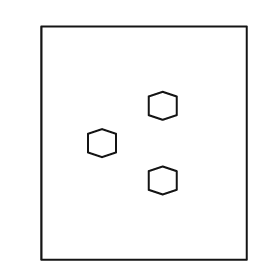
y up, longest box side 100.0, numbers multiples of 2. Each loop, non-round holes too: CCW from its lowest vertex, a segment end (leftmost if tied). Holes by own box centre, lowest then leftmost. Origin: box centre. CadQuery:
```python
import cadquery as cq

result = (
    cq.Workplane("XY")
    .moveTo(-44.0, -50.0)
    .lineTo(44.0, -50.0)
    .lineTo(44.0, 50.0)
    .lineTo(-44.0, 50.0)
    .close()
    .moveTo(8.0, -22.0)
    .lineTo(14.0, -20.0)
    .lineTo(14.0, -12.0)
    .lineTo(8.0, -10.0)
    .lineTo(2.0, -12.0)
    .lineTo(2.0, -20.0)
    .close()
    .moveTo(-18.0, -6.0)
    .lineTo(-12.0, -4.0)
    .lineTo(-12.0, 4.0)
    .lineTo(-18.0, 6.0)
    .lineTo(-24.0, 4.0)
    .lineTo(-24.0, -4.0)
    .close()
    .moveTo(8.0, 10.0)
    .lineTo(14.0, 12.0)
    .lineTo(14.0, 20.0)
    .lineTo(8.0, 22.0)
    .lineTo(2.0, 20.0)
    .lineTo(2.0, 12.0)
    .close()
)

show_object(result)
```